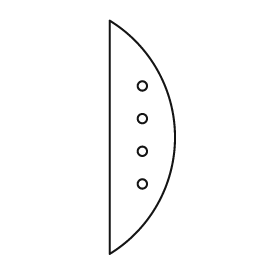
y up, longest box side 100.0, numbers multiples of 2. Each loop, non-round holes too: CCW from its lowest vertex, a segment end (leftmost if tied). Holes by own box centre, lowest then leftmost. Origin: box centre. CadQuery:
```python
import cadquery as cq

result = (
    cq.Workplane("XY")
    .moveTo(-14.0, -50.0)
    .threePointArc((14.0, 0.0), (-14.0, 50.0))
    .close()
    .moveTo(0.0, -20.0)
    .circle(2.0)
    .moveTo(0.0, -6.0)
    .circle(2.0)
    .moveTo(0.0, 8.0)
    .circle(2.0)
    .moveTo(0.0, 22.0)
    .circle(2.0)
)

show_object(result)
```